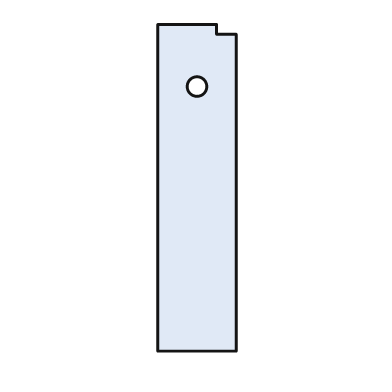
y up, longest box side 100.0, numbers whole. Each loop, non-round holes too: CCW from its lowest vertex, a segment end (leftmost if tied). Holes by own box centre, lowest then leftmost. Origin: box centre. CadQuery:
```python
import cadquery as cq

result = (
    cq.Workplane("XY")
    .moveTo(-12.0, -50.0)
    .lineTo(12.0, -50.0)
    .lineTo(12.0, 47.0)
    .lineTo(6.0, 47.0)
    .lineTo(6.0, 50.0)
    .lineTo(-12.0, 50.0)
    .close()
    .moveTo(0.0, 31.0)
    .circle(3.0)
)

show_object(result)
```